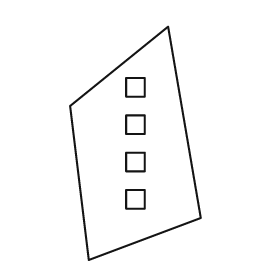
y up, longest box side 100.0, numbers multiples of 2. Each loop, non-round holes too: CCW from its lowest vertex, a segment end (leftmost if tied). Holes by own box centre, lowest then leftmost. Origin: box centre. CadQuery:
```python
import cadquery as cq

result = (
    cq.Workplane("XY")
    .moveTo(-20.0, -50.0)
    .lineTo(28.0, -32.0)
    .lineTo(14.0, 50.0)
    .lineTo(-28.0, 16.0)
    .close()
    .moveTo(-4.0, -28.0)
    .lineTo(4.0, -28.0)
    .lineTo(4.0, -20.0)
    .lineTo(-4.0, -20.0)
    .close()
    .moveTo(-4.0, -12.0)
    .lineTo(4.0, -12.0)
    .lineTo(4.0, -4.0)
    .lineTo(-4.0, -4.0)
    .close()
    .moveTo(-4.0, 4.0)
    .lineTo(4.0, 4.0)
    .lineTo(4.0, 12.0)
    .lineTo(-4.0, 12.0)
    .close()
    .moveTo(-4.0, 20.0)
    .lineTo(4.0, 20.0)
    .lineTo(4.0, 28.0)
    .lineTo(-4.0, 28.0)
    .close()
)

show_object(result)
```